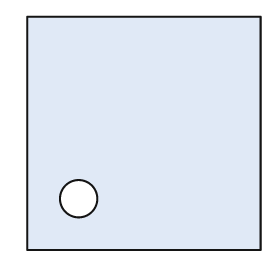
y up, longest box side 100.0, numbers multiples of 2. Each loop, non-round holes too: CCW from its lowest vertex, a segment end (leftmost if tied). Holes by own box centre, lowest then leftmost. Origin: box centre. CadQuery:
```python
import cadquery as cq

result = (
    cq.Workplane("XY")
    .moveTo(-50.0, -50.0)
    .lineTo(50.0, -50.0)
    .lineTo(50.0, 50.0)
    .lineTo(-50.0, 50.0)
    .close()
    .moveTo(-28.0, -28.0)
    .circle(8.0)
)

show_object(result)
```